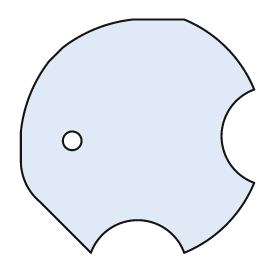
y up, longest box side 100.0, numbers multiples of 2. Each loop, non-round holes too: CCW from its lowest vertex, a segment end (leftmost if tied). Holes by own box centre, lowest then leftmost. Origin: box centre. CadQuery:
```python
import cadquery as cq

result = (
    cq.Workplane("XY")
    .moveTo(-20.0, -50.0)
    .threePointArc((0.0, -36.0), (20.0, -50.0))
    .threePointArc((38.0, -38.0), (50.0, -20.0))
    .threePointArc((36.0, 0.0), (50.0, 20.0))
    .threePointArc((38.0, 38.0), (20.0, 50.0))
    .lineTo(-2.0, 50.0)
    .threePointArc((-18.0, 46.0), (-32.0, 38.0))
    .lineTo(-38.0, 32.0)
    .threePointArc((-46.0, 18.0), (-50.0, 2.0))
    .lineTo(-50.0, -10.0)
    .threePointArc((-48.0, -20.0), (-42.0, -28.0))
    .close()
    .moveTo(-28.0, -2.0)
    .circle(4.0)
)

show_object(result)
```